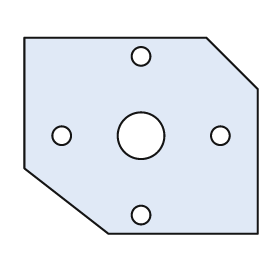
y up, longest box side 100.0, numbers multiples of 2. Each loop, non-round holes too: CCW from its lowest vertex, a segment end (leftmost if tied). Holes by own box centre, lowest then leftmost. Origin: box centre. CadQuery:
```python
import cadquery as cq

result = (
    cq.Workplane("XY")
    .moveTo(-14.0, -42.0)
    .lineTo(50.0, -42.0)
    .lineTo(50.0, 20.0)
    .lineTo(28.0, 42.0)
    .lineTo(-50.0, 42.0)
    .lineTo(-50.0, -14.0)
    .close()
    .moveTo(0.0, -34.0)
    .circle(4.0)
    .moveTo(-34.0, 0.0)
    .circle(4.0)
    .moveTo(0.0, 0.0)
    .circle(10.0)
    .moveTo(34.0, 0.0)
    .circle(4.0)
    .moveTo(0.0, 34.0)
    .circle(4.0)
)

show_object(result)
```